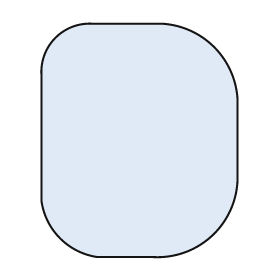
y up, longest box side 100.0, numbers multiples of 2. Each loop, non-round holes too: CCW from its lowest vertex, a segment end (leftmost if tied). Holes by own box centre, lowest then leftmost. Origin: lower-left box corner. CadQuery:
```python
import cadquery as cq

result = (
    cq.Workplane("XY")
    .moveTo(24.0, 0.0)
    .lineTo(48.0, 0.0)
    .threePointArc((74.0, 10.0), (84.0, 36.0))
    .lineTo(84.0, 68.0)
    .threePointArc((74.0, 90.0), (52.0, 100.0))
    .lineTo(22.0, 100.0)
    .threePointArc((6.0, 94.0), (0.0, 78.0))
    .lineTo(0.0, 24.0)
    .threePointArc((8.0, 8.0), (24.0, 0.0))
    .close()
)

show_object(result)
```